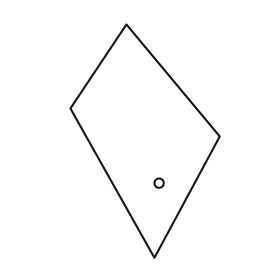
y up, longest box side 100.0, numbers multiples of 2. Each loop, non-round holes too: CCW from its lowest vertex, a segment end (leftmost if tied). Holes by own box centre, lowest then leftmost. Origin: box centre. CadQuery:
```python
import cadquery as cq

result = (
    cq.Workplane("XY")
    .moveTo(4.0, -50.0)
    .lineTo(32.0, 2.0)
    .lineTo(-8.0, 50.0)
    .lineTo(-32.0, 14.0)
    .close()
    .moveTo(6.0, -18.0)
    .circle(2.0)
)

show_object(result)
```